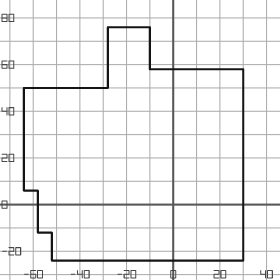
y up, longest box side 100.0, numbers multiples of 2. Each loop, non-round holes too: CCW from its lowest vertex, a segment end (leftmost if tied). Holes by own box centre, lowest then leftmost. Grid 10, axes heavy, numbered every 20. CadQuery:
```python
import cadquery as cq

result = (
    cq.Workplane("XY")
    .moveTo(-52.0, -24.0)
    .lineTo(30.0, -24.0)
    .lineTo(30.0, 58.0)
    .lineTo(-10.0, 58.0)
    .lineTo(-10.0, 76.0)
    .lineTo(-28.0, 76.0)
    .lineTo(-28.0, 50.0)
    .lineTo(-64.0, 50.0)
    .lineTo(-64.0, 6.0)
    .lineTo(-58.0, 6.0)
    .lineTo(-58.0, -12.0)
    .lineTo(-52.0, -12.0)
    .close()
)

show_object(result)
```